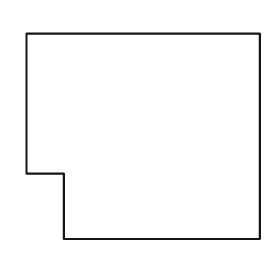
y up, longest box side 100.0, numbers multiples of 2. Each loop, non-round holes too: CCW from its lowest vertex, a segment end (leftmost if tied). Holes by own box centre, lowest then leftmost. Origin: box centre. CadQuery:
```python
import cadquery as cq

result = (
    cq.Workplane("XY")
    .moveTo(-34.0, -44.0)
    .lineTo(50.0, -44.0)
    .lineTo(50.0, 44.0)
    .lineTo(-50.0, 44.0)
    .lineTo(-50.0, -16.0)
    .lineTo(-34.0, -16.0)
    .close()
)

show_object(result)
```